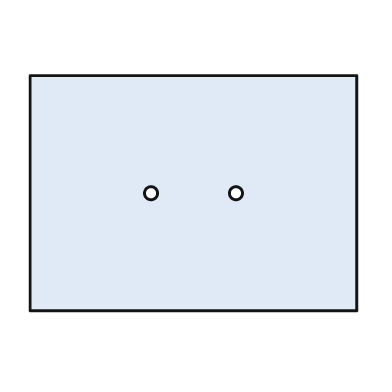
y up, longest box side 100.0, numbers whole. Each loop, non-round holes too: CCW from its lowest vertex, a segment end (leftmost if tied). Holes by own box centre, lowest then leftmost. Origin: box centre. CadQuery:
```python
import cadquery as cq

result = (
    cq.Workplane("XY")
    .moveTo(-50.0, -36.0)
    .lineTo(50.0, -36.0)
    .lineTo(50.0, 36.0)
    .lineTo(-50.0, 36.0)
    .close()
    .moveTo(-13.0, 0.0)
    .circle(2.0)
    .moveTo(13.0, 0.0)
    .circle(2.0)
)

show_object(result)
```